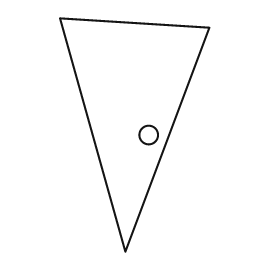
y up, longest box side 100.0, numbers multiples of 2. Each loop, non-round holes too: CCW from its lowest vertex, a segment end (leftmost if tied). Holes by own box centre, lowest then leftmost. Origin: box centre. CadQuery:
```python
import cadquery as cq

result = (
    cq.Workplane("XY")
    .moveTo(-4.0, -50.0)
    .lineTo(32.0, 46.0)
    .lineTo(-32.0, 50.0)
    .close()
    .moveTo(6.0, 0.0)
    .circle(4.0)
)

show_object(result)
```